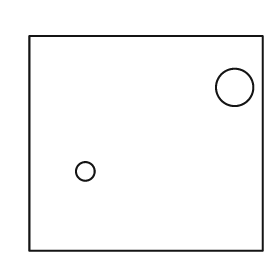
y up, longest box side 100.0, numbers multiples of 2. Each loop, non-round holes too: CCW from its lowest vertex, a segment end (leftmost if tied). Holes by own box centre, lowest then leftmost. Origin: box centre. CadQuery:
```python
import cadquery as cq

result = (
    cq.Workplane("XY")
    .moveTo(-50.0, -46.0)
    .lineTo(50.0, -46.0)
    .lineTo(50.0, 46.0)
    .lineTo(-50.0, 46.0)
    .close()
    .moveTo(-26.0, -12.0)
    .circle(4.0)
    .moveTo(38.0, 24.0)
    .circle(8.0)
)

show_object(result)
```